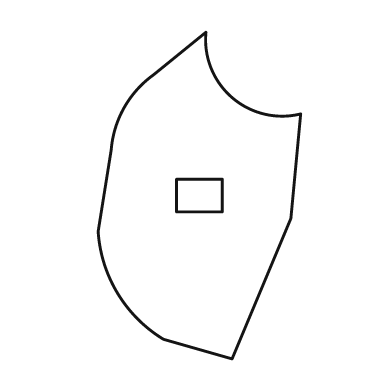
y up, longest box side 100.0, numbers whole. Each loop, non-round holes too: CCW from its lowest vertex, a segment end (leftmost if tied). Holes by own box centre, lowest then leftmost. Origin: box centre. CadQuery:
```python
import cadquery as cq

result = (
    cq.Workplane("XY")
    .moveTo(10.0, -50.0)
    .lineTo(28.0, -7.0)
    .lineTo(31.0, 25.0)
    .threePointArc((10.0, 30.0), (2.0, 50.0))
    .lineTo(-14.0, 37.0)
    .threePointArc((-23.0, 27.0), (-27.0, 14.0))
    .lineTo(-31.0, -11.0)
    .threePointArc((-25.0, -30.0), (-11.0, -44.0))
    .close()
    .moveTo(-7.0, -5.0)
    .lineTo(7.0, -5.0)
    .lineTo(7.0, 5.0)
    .lineTo(-7.0, 5.0)
    .close()
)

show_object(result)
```